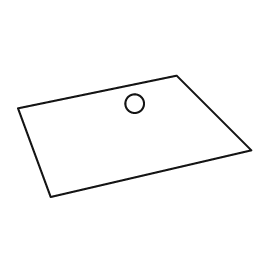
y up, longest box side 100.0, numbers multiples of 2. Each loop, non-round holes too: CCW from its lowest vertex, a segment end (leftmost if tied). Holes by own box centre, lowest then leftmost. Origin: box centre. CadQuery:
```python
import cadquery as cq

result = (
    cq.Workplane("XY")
    .moveTo(-36.0, -26.0)
    .lineTo(50.0, -6.0)
    .lineTo(18.0, 26.0)
    .lineTo(-50.0, 12.0)
    .close()
    .moveTo(0.0, 14.0)
    .circle(4.0)
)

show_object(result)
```